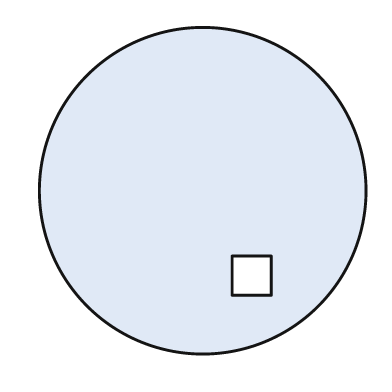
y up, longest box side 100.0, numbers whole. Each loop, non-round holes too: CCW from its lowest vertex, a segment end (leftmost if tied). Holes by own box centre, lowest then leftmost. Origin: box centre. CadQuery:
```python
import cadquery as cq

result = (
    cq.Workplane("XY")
    .moveTo(0.0, 0.0)
    .circle(50.0)
    .moveTo(9.0, -32.0)
    .lineTo(21.0, -32.0)
    .lineTo(21.0, -20.0)
    .lineTo(9.0, -20.0)
    .close()
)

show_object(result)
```